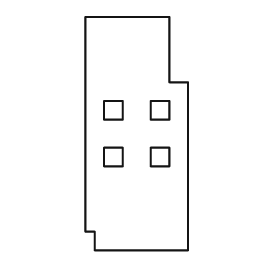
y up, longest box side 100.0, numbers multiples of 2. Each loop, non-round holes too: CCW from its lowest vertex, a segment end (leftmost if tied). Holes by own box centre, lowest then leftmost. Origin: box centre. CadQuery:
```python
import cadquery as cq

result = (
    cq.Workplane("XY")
    .moveTo(-18.0, -50.0)
    .lineTo(22.0, -50.0)
    .lineTo(22.0, 22.0)
    .lineTo(14.0, 22.0)
    .lineTo(14.0, 50.0)
    .lineTo(-22.0, 50.0)
    .lineTo(-22.0, -42.0)
    .lineTo(-18.0, -42.0)
    .close()
    .moveTo(-14.0, -14.0)
    .lineTo(-6.0, -14.0)
    .lineTo(-6.0, -6.0)
    .lineTo(-14.0, -6.0)
    .close()
    .moveTo(6.0, -14.0)
    .lineTo(14.0, -14.0)
    .lineTo(14.0, -6.0)
    .lineTo(6.0, -6.0)
    .close()
    .moveTo(-14.0, 6.0)
    .lineTo(-6.0, 6.0)
    .lineTo(-6.0, 14.0)
    .lineTo(-14.0, 14.0)
    .close()
    .moveTo(6.0, 6.0)
    .lineTo(14.0, 6.0)
    .lineTo(14.0, 14.0)
    .lineTo(6.0, 14.0)
    .close()
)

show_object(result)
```